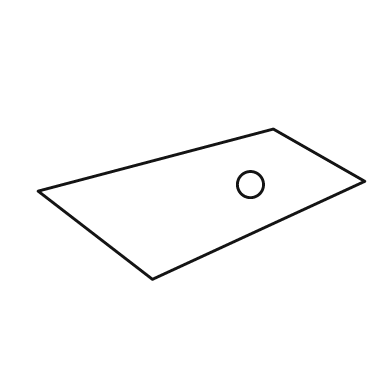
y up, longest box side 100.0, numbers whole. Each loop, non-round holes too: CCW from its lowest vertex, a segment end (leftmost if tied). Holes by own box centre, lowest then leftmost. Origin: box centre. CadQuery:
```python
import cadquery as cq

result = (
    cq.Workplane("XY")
    .moveTo(-15.0, -23.0)
    .lineTo(50.0, 7.0)
    .lineTo(22.0, 23.0)
    .lineTo(-50.0, 4.0)
    .close()
    .moveTo(15.0, 6.0)
    .circle(4.0)
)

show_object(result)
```